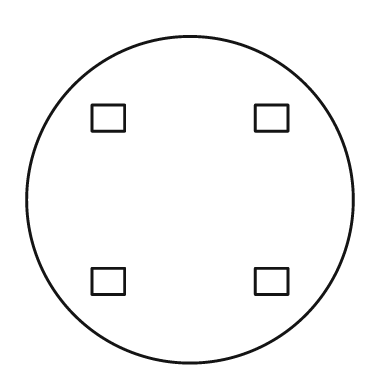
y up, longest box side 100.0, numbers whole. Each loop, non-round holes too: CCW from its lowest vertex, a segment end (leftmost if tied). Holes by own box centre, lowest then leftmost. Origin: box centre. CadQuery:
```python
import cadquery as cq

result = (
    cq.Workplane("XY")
    .moveTo(0.0, 0.0)
    .circle(50.0)
    .moveTo(-30.0, -29.0)
    .lineTo(-20.0, -29.0)
    .lineTo(-20.0, -21.0)
    .lineTo(-30.0, -21.0)
    .close()
    .moveTo(20.0, -29.0)
    .lineTo(30.0, -29.0)
    .lineTo(30.0, -21.0)
    .lineTo(20.0, -21.0)
    .close()
    .moveTo(-30.0, 21.0)
    .lineTo(-20.0, 21.0)
    .lineTo(-20.0, 29.0)
    .lineTo(-30.0, 29.0)
    .close()
    .moveTo(20.0, 21.0)
    .lineTo(30.0, 21.0)
    .lineTo(30.0, 29.0)
    .lineTo(20.0, 29.0)
    .close()
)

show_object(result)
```